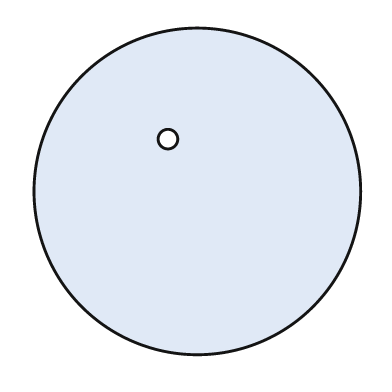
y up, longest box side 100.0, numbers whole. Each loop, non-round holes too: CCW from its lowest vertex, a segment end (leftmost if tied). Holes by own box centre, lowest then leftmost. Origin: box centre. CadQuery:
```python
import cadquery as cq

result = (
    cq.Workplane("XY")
    .moveTo(0.0, 0.0)
    .circle(50.0)
    .moveTo(-9.0, 16.0)
    .circle(3.0)
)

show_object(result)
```